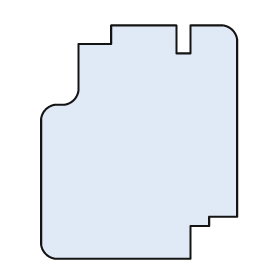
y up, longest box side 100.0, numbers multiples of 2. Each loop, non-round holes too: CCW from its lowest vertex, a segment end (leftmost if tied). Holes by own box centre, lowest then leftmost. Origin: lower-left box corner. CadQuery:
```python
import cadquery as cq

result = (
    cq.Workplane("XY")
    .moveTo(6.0, 0.0)
    .lineTo(64.0, 0.0)
    .lineTo(64.0, 14.0)
    .lineTo(72.0, 14.0)
    .lineTo(72.0, 18.0)
    .lineTo(84.0, 18.0)
    .lineTo(84.0, 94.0)
    .threePointArc((82.0, 98.0), (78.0, 100.0))
    .lineTo(64.0, 100.0)
    .lineTo(64.0, 88.0)
    .lineTo(58.0, 88.0)
    .lineTo(58.0, 100.0)
    .lineTo(30.0, 100.0)
    .lineTo(30.0, 92.0)
    .lineTo(16.0, 92.0)
    .lineTo(16.0, 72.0)
    .threePointArc((14.0, 68.0), (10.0, 66.0))
    .lineTo(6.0, 66.0)
    .threePointArc((2.0, 64.0), (0.0, 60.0))
    .lineTo(0.0, 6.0)
    .threePointArc((2.0, 2.0), (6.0, 0.0))
    .close()
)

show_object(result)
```